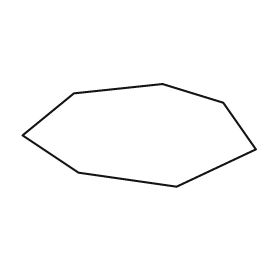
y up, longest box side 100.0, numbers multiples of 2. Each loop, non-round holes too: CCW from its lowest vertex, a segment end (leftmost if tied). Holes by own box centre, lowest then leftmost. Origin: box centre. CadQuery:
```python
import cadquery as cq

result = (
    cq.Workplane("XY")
    .moveTo(16.0, -22.0)
    .lineTo(50.0, -6.0)
    .lineTo(36.0, 14.0)
    .lineTo(10.0, 22.0)
    .lineTo(-28.0, 18.0)
    .lineTo(-50.0, 0.0)
    .lineTo(-26.0, -16.0)
    .close()
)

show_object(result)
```